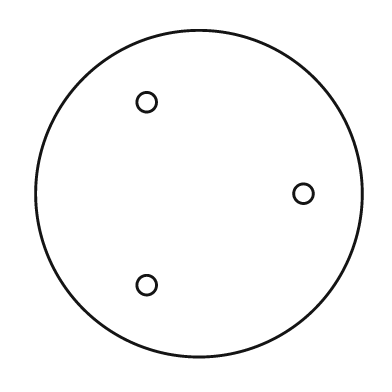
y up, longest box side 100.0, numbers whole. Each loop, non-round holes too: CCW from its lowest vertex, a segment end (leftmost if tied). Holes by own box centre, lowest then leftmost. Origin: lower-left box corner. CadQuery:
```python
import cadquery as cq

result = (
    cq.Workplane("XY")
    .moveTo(50.0, 50.0)
    .circle(50.0)
    .moveTo(34.0, 22.0)
    .circle(3.0)
    .moveTo(82.0, 50.0)
    .circle(3.0)
    .moveTo(34.0, 78.0)
    .circle(3.0)
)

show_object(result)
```